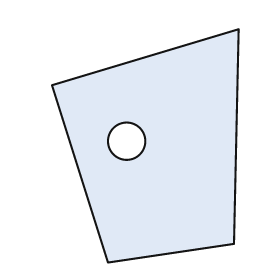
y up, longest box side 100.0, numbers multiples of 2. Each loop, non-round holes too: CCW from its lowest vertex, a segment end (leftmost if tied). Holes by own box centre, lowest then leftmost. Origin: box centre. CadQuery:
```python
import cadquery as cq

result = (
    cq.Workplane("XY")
    .moveTo(-16.0, -50.0)
    .lineTo(38.0, -42.0)
    .lineTo(40.0, 50.0)
    .lineTo(-40.0, 26.0)
    .close()
    .moveTo(-8.0, 2.0)
    .circle(8.0)
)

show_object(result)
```